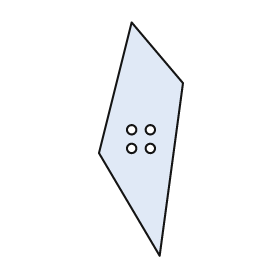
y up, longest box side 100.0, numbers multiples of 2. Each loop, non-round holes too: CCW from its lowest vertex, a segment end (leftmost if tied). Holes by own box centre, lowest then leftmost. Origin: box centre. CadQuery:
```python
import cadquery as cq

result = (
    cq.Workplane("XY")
    .moveTo(8.0, -50.0)
    .lineTo(18.0, 24.0)
    .lineTo(-4.0, 50.0)
    .lineTo(-18.0, -6.0)
    .close()
    .moveTo(-4.0, -4.0)
    .circle(2.0)
    .moveTo(4.0, -4.0)
    .circle(2.0)
    .moveTo(-4.0, 4.0)
    .circle(2.0)
    .moveTo(4.0, 4.0)
    .circle(2.0)
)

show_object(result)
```